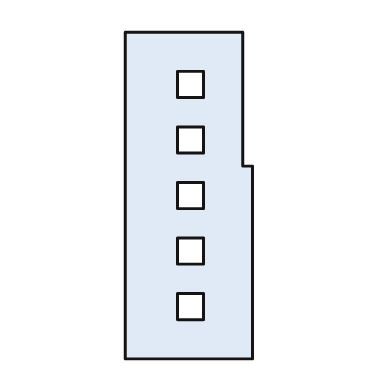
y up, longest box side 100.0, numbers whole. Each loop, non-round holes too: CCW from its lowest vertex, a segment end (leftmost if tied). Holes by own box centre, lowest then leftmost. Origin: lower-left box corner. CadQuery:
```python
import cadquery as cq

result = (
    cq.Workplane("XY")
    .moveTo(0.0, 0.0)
    .lineTo(39.0, 0.0)
    .lineTo(39.0, 59.0)
    .lineTo(36.0, 59.0)
    .lineTo(36.0, 100.0)
    .lineTo(0.0, 100.0)
    .close()
    .moveTo(16.0, 12.0)
    .lineTo(24.0, 12.0)
    .lineTo(24.0, 20.0)
    .lineTo(16.0, 20.0)
    .close()
    .moveTo(16.0, 29.0)
    .lineTo(24.0, 29.0)
    .lineTo(24.0, 37.0)
    .lineTo(16.0, 37.0)
    .close()
    .moveTo(16.0, 46.0)
    .lineTo(24.0, 46.0)
    .lineTo(24.0, 54.0)
    .lineTo(16.0, 54.0)
    .close()
    .moveTo(16.0, 63.0)
    .lineTo(24.0, 63.0)
    .lineTo(24.0, 71.0)
    .lineTo(16.0, 71.0)
    .close()
    .moveTo(16.0, 80.0)
    .lineTo(24.0, 80.0)
    .lineTo(24.0, 88.0)
    .lineTo(16.0, 88.0)
    .close()
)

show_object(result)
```